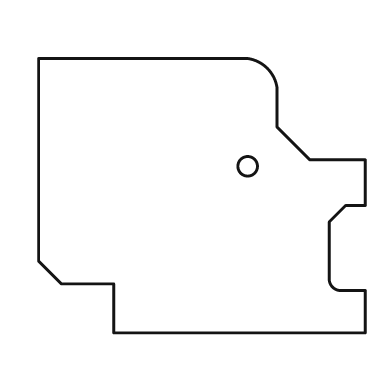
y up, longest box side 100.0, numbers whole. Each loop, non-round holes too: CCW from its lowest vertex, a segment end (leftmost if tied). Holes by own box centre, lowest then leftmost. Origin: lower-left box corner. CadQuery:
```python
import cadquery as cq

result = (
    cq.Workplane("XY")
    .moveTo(23.0, 0.0)
    .lineTo(100.0, 0.0)
    .lineTo(100.0, 13.0)
    .lineTo(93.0, 13.0)
    .threePointArc((90.0, 14.0), (89.0, 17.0))
    .lineTo(89.0, 34.0)
    .lineTo(94.0, 39.0)
    .lineTo(100.0, 39.0)
    .lineTo(100.0, 53.0)
    .lineTo(83.0, 53.0)
    .lineTo(73.0, 63.0)
    .lineTo(73.0, 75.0)
    .threePointArc((70.0, 81.0), (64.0, 84.0))
    .lineTo(0.0, 84.0)
    .lineTo(0.0, 22.0)
    .lineTo(7.0, 15.0)
    .lineTo(23.0, 15.0)
    .close()
    .moveTo(64.0, 51.0)
    .circle(3.0)
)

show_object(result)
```